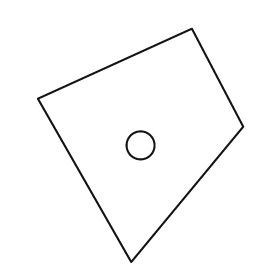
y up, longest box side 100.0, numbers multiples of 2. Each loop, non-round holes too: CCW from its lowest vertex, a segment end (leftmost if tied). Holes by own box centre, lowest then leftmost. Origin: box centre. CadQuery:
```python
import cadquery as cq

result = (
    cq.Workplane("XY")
    .moveTo(-4.0, -50.0)
    .lineTo(44.0, 8.0)
    .lineTo(22.0, 50.0)
    .lineTo(-44.0, 20.0)
    .close()
    .moveTo(0.0, 0.0)
    .circle(6.0)
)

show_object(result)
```